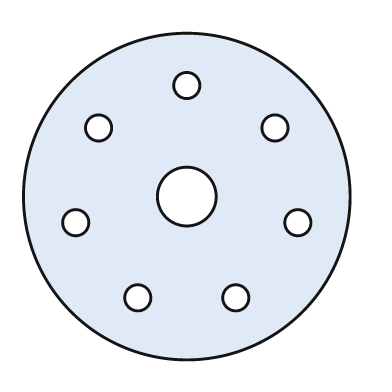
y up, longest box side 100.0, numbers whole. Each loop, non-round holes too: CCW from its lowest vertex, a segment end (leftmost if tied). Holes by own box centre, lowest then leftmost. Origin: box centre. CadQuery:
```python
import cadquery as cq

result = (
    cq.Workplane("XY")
    .moveTo(0.0, 0.0)
    .circle(50.0)
    .moveTo(-15.0, -31.0)
    .circle(4.0)
    .moveTo(15.0, -31.0)
    .circle(4.0)
    .moveTo(-34.0, -8.0)
    .circle(4.0)
    .moveTo(34.0, -8.0)
    .circle(4.0)
    .moveTo(0.0, 0.0)
    .circle(9.0)
    .moveTo(-27.0, 21.0)
    .circle(4.0)
    .moveTo(27.0, 21.0)
    .circle(4.0)
    .moveTo(0.0, 34.0)
    .circle(4.0)
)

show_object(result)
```